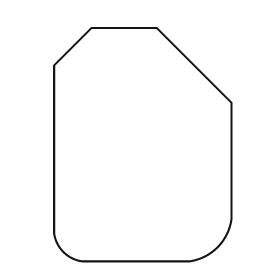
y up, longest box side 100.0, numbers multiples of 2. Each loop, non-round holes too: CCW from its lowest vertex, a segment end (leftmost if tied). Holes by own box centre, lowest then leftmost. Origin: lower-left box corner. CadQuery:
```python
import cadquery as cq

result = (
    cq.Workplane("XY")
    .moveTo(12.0, 0.0)
    .lineTo(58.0, 0.0)
    .threePointArc((70.0, 6.0), (76.0, 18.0))
    .lineTo(76.0, 68.0)
    .lineTo(44.0, 100.0)
    .lineTo(16.0, 100.0)
    .lineTo(0.0, 84.0)
    .lineTo(0.0, 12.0)
    .threePointArc((4.0, 4.0), (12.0, 0.0))
    .close()
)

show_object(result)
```